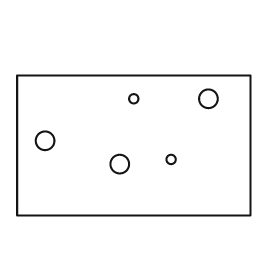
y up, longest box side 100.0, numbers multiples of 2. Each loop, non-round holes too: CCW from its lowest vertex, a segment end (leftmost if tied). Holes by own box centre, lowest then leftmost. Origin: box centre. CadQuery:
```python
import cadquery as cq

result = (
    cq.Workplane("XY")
    .moveTo(-50.0, -30.0)
    .lineTo(50.0, -30.0)
    .lineTo(50.0, 30.0)
    .lineTo(-50.0, 30.0)
    .close()
    .moveTo(-6.0, -8.0)
    .circle(4.0)
    .moveTo(16.0, -6.0)
    .circle(2.0)
    .moveTo(-38.0, 2.0)
    .circle(4.0)
    .moveTo(0.0, 20.0)
    .circle(2.0)
    .moveTo(32.0, 20.0)
    .circle(4.0)
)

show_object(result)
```